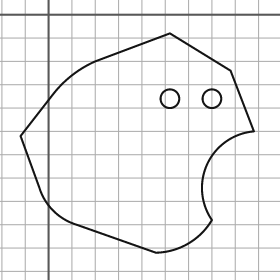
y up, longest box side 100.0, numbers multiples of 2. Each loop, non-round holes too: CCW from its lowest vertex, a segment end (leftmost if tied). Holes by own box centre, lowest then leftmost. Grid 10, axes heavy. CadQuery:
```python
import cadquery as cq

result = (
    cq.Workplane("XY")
    .moveTo(46.0, -102.0)
    .threePointArc((60.0, -98.0), (70.0, -88.0))
    .threePointArc((68.0, -64.0), (88.0, -50.0))
    .lineTo(78.0, -24.0)
    .lineTo(52.0, -8.0)
    .lineTo(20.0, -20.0)
    .threePointArc((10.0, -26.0), (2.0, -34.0))
    .lineTo(-12.0, -52.0)
    .lineTo(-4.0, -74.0)
    .threePointArc((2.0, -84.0), (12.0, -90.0))
    .close()
    .moveTo(52.0, -36.0)
    .circle(4.0)
    .moveTo(70.0, -36.0)
    .circle(4.0)
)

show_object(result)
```